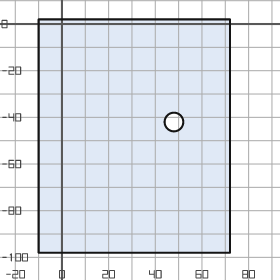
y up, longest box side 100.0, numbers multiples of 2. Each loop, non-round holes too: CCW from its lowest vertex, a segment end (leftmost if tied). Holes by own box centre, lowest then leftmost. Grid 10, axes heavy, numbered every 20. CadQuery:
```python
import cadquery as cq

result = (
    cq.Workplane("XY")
    .moveTo(-10.0, -98.0)
    .lineTo(72.0, -98.0)
    .lineTo(72.0, 2.0)
    .lineTo(-10.0, 2.0)
    .close()
    .moveTo(48.0, -42.0)
    .circle(4.0)
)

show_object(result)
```